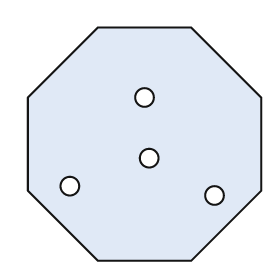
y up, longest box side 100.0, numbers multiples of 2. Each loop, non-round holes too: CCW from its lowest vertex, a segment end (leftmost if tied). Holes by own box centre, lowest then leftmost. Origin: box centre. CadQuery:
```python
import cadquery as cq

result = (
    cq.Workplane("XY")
    .moveTo(-20.0, -50.0)
    .lineTo(20.0, -50.0)
    .lineTo(50.0, -20.0)
    .lineTo(50.0, 20.0)
    .lineTo(20.0, 50.0)
    .lineTo(-20.0, 50.0)
    .lineTo(-50.0, 20.0)
    .lineTo(-50.0, -20.0)
    .close()
    .moveTo(30.0, -22.0)
    .circle(4.0)
    .moveTo(-32.0, -18.0)
    .circle(4.0)
    .moveTo(2.0, -6.0)
    .circle(4.0)
    .moveTo(0.0, 20.0)
    .circle(4.0)
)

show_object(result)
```